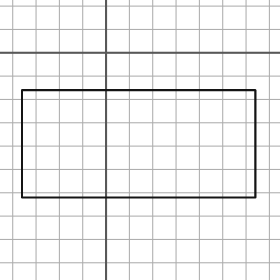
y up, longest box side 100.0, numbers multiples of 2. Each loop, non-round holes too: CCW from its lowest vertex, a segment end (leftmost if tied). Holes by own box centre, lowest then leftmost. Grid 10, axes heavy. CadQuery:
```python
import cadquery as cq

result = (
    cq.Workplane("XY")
    .moveTo(-36.0, -62.0)
    .lineTo(64.0, -62.0)
    .lineTo(64.0, -16.0)
    .lineTo(-36.0, -16.0)
    .close()
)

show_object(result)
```